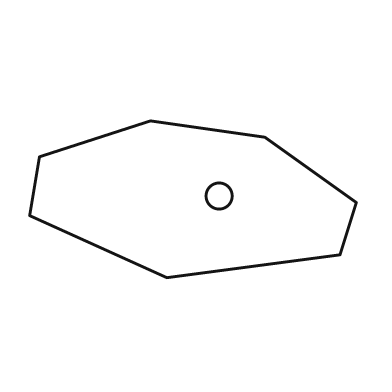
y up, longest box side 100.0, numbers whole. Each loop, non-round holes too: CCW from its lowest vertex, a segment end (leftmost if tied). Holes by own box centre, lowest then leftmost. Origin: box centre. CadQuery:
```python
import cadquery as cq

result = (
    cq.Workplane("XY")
    .moveTo(-8.0, -24.0)
    .lineTo(45.0, -17.0)
    .lineTo(50.0, -1.0)
    .lineTo(22.0, 19.0)
    .lineTo(-13.0, 24.0)
    .lineTo(-47.0, 13.0)
    .lineTo(-50.0, -5.0)
    .close()
    .moveTo(8.0, 1.0)
    .circle(4.0)
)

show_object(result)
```